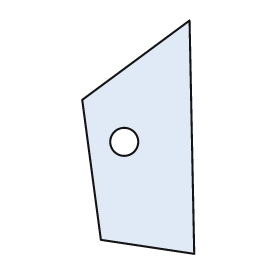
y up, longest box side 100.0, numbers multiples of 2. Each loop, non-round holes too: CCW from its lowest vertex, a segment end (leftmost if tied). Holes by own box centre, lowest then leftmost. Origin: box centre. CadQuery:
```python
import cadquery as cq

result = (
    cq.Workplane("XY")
    .moveTo(24.0, -50.0)
    .lineTo(22.0, 50.0)
    .lineTo(-24.0, 16.0)
    .lineTo(-16.0, -44.0)
    .close()
    .moveTo(-6.0, -2.0)
    .circle(6.0)
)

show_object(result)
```